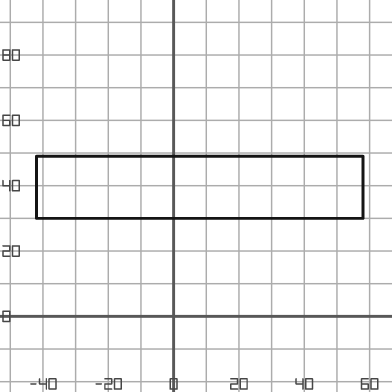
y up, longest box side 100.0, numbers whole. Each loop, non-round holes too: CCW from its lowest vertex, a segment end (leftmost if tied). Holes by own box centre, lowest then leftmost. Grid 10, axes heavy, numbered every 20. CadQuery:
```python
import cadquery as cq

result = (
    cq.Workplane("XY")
    .moveTo(-42.0, 30.0)
    .lineTo(58.0, 30.0)
    .lineTo(58.0, 49.0)
    .lineTo(-42.0, 49.0)
    .close()
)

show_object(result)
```